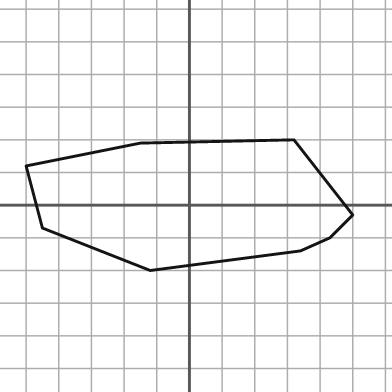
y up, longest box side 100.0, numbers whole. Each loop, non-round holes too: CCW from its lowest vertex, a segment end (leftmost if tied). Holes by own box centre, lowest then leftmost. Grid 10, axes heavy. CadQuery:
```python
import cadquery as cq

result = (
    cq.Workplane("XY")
    .moveTo(-12.0, -20.0)
    .lineTo(34.0, -14.0)
    .lineTo(43.0, -10.0)
    .lineTo(50.0, -3.0)
    .lineTo(32.0, 20.0)
    .lineTo(-15.0, 19.0)
    .lineTo(-50.0, 12.0)
    .lineTo(-45.0, -7.0)
    .close()
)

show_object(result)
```